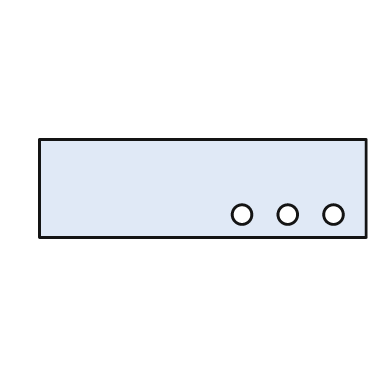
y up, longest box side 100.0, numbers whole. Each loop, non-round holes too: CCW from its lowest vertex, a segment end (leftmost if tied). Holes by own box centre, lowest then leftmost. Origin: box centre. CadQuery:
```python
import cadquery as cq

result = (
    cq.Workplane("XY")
    .moveTo(-50.0, -15.0)
    .lineTo(50.0, -15.0)
    .lineTo(50.0, 15.0)
    .lineTo(-50.0, 15.0)
    .close()
    .moveTo(12.0, -8.0)
    .circle(3.0)
    .moveTo(26.0, -8.0)
    .circle(3.0)
    .moveTo(40.0, -8.0)
    .circle(3.0)
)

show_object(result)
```